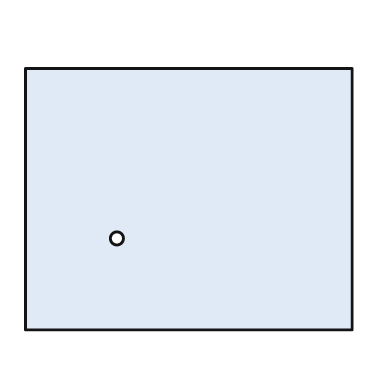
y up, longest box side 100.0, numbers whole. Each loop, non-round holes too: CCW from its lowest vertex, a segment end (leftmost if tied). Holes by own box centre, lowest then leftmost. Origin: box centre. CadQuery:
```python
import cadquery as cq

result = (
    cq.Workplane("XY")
    .moveTo(-50.0, -40.0)
    .lineTo(50.0, -40.0)
    .lineTo(50.0, 40.0)
    .lineTo(-50.0, 40.0)
    .close()
    .moveTo(-22.0, -12.0)
    .circle(2.0)
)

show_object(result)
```